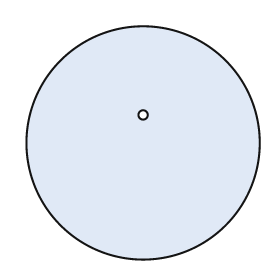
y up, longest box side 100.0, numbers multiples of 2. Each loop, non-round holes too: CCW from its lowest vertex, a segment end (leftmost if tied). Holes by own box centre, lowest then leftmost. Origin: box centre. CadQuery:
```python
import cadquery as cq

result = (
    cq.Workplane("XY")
    .moveTo(0.0, 0.0)
    .circle(50.0)
    .moveTo(0.0, 12.0)
    .circle(2.0)
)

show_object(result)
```